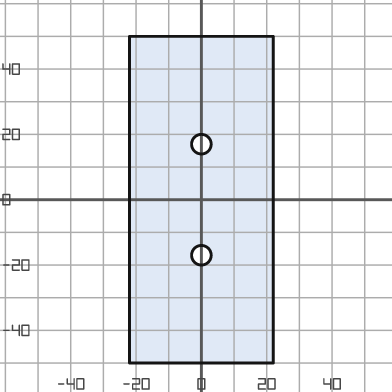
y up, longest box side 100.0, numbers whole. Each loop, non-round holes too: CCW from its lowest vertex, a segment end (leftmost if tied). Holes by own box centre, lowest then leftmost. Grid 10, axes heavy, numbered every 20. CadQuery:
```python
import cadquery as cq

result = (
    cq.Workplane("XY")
    .moveTo(-22.0, -50.0)
    .lineTo(22.0, -50.0)
    .lineTo(22.0, 50.0)
    .lineTo(-22.0, 50.0)
    .close()
    .moveTo(0.0, -17.0)
    .circle(3.0)
    .moveTo(0.0, 17.0)
    .circle(3.0)
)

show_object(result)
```